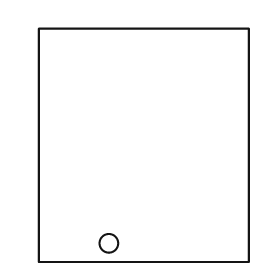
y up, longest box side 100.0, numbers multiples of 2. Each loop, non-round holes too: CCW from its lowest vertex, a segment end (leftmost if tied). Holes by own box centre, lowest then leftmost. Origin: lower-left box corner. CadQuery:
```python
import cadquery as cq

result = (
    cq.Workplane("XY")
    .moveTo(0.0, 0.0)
    .lineTo(90.0, 0.0)
    .lineTo(90.0, 100.0)
    .lineTo(0.0, 100.0)
    .close()
    .moveTo(30.0, 8.0)
    .circle(4.0)
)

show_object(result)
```